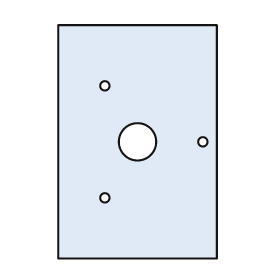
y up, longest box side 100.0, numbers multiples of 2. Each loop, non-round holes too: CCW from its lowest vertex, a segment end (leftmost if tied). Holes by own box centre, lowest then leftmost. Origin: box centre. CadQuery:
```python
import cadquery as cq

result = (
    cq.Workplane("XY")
    .moveTo(-34.0, -50.0)
    .lineTo(34.0, -50.0)
    .lineTo(34.0, 50.0)
    .lineTo(-34.0, 50.0)
    .close()
    .moveTo(-14.0, -24.0)
    .circle(2.0)
    .moveTo(0.0, 0.0)
    .circle(8.0)
    .moveTo(28.0, 0.0)
    .circle(2.0)
    .moveTo(-14.0, 24.0)
    .circle(2.0)
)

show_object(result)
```